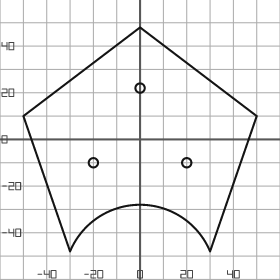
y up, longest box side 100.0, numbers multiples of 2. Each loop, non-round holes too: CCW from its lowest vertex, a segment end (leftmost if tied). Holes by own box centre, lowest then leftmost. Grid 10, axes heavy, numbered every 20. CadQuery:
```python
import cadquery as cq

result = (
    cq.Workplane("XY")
    .moveTo(-30.0, -48.0)
    .threePointArc((0.0, -28.0), (30.0, -48.0))
    .lineTo(50.0, 10.0)
    .lineTo(0.0, 48.0)
    .lineTo(-50.0, 10.0)
    .close()
    .moveTo(-20.0, -10.0)
    .circle(2.0)
    .moveTo(20.0, -10.0)
    .circle(2.0)
    .moveTo(0.0, 22.0)
    .circle(2.0)
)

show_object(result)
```